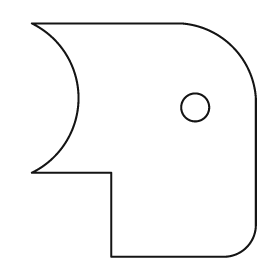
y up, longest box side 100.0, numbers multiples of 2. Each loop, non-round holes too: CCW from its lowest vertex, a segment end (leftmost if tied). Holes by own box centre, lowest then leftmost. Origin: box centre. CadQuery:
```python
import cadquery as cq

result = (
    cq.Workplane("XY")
    .moveTo(-14.0, -50.0)
    .lineTo(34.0, -50.0)
    .threePointArc((44.0, -46.0), (48.0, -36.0))
    .lineTo(48.0, 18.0)
    .threePointArc((38.0, 40.0), (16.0, 50.0))
    .lineTo(-48.0, 50.0)
    .threePointArc((-28.0, 18.0), (-48.0, -14.0))
    .lineTo(-14.0, -14.0)
    .close()
    .moveTo(22.0, 14.0)
    .circle(6.0)
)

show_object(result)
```